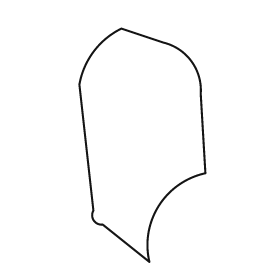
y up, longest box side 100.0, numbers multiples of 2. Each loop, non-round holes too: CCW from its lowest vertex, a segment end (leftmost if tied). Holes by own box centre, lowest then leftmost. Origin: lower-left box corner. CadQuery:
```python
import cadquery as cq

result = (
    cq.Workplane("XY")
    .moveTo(30.0, 0.0)
    .threePointArc((34.0, 24.0), (54.0, 38.0))
    .lineTo(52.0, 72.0)
    .threePointArc((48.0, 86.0), (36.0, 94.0))
    .lineTo(18.0, 100.0)
    .threePointArc((6.0, 90.0), (0.0, 76.0))
    .lineTo(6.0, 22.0)
    .threePointArc((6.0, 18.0), (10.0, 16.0))
    .close()
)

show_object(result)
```